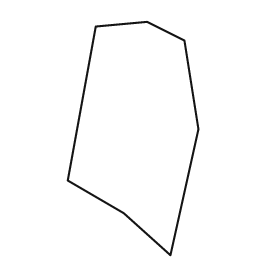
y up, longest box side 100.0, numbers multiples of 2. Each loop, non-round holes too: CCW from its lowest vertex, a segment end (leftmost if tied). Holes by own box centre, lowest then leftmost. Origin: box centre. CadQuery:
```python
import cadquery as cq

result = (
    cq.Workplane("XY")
    .moveTo(16.0, -50.0)
    .lineTo(28.0, 4.0)
    .lineTo(22.0, 42.0)
    .lineTo(6.0, 50.0)
    .lineTo(-16.0, 48.0)
    .lineTo(-28.0, -18.0)
    .lineTo(-4.0, -32.0)
    .close()
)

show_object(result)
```